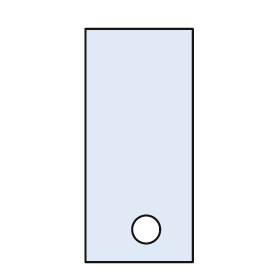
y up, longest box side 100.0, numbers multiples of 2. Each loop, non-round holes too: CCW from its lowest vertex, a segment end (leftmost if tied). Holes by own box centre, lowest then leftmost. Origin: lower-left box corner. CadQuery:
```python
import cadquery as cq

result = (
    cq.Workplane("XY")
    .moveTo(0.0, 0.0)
    .lineTo(46.0, 0.0)
    .lineTo(46.0, 100.0)
    .lineTo(0.0, 100.0)
    .close()
    .moveTo(26.0, 14.0)
    .circle(6.0)
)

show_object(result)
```